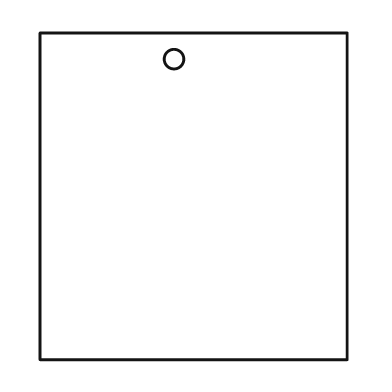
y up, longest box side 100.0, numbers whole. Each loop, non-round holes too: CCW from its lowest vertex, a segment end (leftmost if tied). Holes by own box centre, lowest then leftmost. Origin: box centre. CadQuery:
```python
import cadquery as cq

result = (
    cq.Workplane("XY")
    .moveTo(-47.0, -50.0)
    .lineTo(47.0, -50.0)
    .lineTo(47.0, 50.0)
    .lineTo(-47.0, 50.0)
    .close()
    .moveTo(-6.0, 42.0)
    .circle(3.0)
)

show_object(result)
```